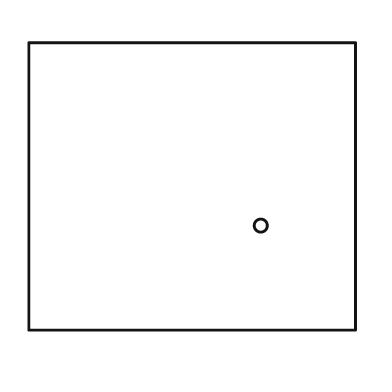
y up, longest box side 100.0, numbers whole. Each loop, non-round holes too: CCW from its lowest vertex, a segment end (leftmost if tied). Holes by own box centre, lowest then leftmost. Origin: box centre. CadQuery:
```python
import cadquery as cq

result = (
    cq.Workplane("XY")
    .moveTo(-50.0, -44.0)
    .lineTo(50.0, -44.0)
    .lineTo(50.0, 44.0)
    .lineTo(-50.0, 44.0)
    .close()
    .moveTo(21.0, -12.0)
    .circle(2.0)
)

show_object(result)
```